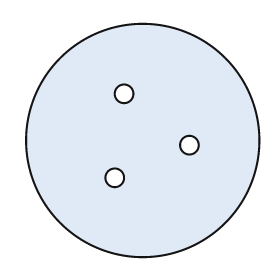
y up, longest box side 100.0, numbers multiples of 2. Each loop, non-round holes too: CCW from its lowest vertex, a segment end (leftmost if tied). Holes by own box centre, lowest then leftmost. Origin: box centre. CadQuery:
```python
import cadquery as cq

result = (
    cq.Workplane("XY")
    .moveTo(0.0, 0.0)
    .circle(50.0)
    .moveTo(-12.0, -16.0)
    .circle(4.0)
    .moveTo(20.0, -2.0)
    .circle(4.0)
    .moveTo(-8.0, 20.0)
    .circle(4.0)
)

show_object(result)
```